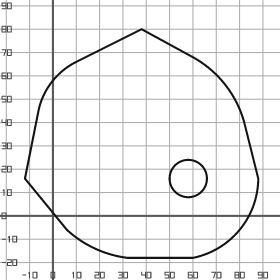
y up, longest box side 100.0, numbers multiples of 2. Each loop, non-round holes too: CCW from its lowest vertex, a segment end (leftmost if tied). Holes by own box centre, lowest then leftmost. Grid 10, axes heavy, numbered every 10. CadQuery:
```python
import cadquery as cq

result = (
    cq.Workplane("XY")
    .moveTo(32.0, -18.0)
    .lineTo(60.0, -18.0)
    .threePointArc((80.0, -6.0), (88.0, 16.0))
    .lineTo(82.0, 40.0)
    .threePointArc((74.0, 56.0), (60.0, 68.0))
    .lineTo(38.0, 80.0)
    .lineTo(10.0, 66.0)
    .threePointArc((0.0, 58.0), (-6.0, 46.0))
    .lineTo(-12.0, 16.0)
    .lineTo(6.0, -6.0)
    .threePointArc((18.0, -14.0), (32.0, -18.0))
    .close()
    .moveTo(58.0, 16.0)
    .circle(8.0)
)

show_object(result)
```